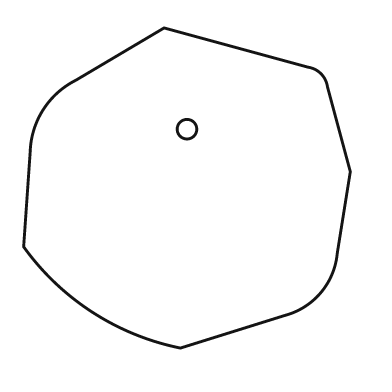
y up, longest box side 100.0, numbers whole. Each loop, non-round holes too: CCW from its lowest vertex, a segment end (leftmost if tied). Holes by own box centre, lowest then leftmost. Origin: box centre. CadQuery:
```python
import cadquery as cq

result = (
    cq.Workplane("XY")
    .moveTo(-2.0, -49.0)
    .lineTo(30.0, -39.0)
    .threePointArc((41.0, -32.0), (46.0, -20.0))
    .lineTo(50.0, 5.0)
    .lineTo(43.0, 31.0)
    .threePointArc((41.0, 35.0), (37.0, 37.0))
    .lineTo(-7.0, 49.0)
    .lineTo(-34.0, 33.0)
    .threePointArc((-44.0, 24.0), (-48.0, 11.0))
    .lineTo(-50.0, -18.0)
    .threePointArc((-29.0, -38.0), (-2.0, -49.0))
    .close()
    .moveTo(0.0, 18.0)
    .circle(3.0)
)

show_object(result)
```